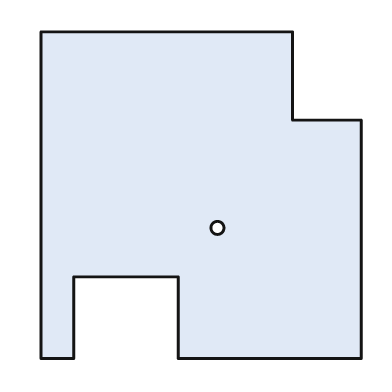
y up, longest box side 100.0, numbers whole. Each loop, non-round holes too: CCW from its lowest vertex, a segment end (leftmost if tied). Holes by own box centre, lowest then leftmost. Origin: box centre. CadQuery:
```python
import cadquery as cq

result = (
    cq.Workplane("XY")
    .moveTo(-49.0, -50.0)
    .lineTo(-39.0, -50.0)
    .lineTo(-39.0, -25.0)
    .lineTo(-7.0, -25.0)
    .lineTo(-7.0, -50.0)
    .lineTo(49.0, -50.0)
    .lineTo(49.0, 23.0)
    .lineTo(28.0, 23.0)
    .lineTo(28.0, 50.0)
    .lineTo(-49.0, 50.0)
    .close()
    .moveTo(5.0, -10.0)
    .circle(2.0)
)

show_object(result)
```